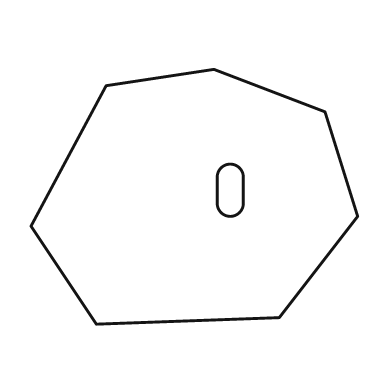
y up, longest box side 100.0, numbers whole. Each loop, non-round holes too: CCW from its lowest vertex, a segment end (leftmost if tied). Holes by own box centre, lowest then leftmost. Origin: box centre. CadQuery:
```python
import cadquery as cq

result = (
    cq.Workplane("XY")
    .moveTo(-30.0, -39.0)
    .lineTo(26.0, -37.0)
    .lineTo(50.0, -6.0)
    .lineTo(40.0, 26.0)
    .lineTo(6.0, 39.0)
    .lineTo(-27.0, 34.0)
    .lineTo(-50.0, -9.0)
    .close()
    .moveTo(7.0, -2.0)
    .threePointArc((11.0, -6.0), (15.0, -2.0))
    .lineTo(15.0, 6.0)
    .threePointArc((11.0, 10.0), (7.0, 6.0))
    .close()
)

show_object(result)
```